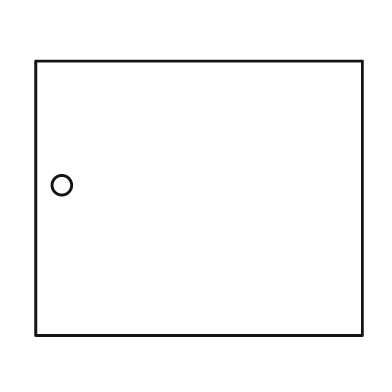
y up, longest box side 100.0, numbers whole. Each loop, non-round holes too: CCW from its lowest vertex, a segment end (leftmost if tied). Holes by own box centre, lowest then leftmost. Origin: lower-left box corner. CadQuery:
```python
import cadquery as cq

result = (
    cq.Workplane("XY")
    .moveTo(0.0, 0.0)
    .lineTo(100.0, 0.0)
    .lineTo(100.0, 84.0)
    .lineTo(0.0, 84.0)
    .close()
    .moveTo(8.0, 46.0)
    .circle(3.0)
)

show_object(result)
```